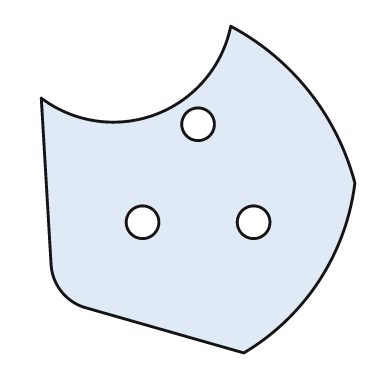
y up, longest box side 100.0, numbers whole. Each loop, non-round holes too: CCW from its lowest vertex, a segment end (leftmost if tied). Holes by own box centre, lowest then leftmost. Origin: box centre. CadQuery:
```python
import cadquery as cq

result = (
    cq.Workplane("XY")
    .moveTo(14.0, -50.0)
    .threePointArc((37.0, -28.0), (48.0, 2.0))
    .threePointArc((34.0, 30.0), (10.0, 50.0))
    .threePointArc((-13.0, 23.0), (-48.0, 28.0))
    .lineTo(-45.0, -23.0)
    .threePointArc((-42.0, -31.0), (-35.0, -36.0))
    .close()
    .moveTo(-17.0, -10.0)
    .circle(5.0)
    .moveTo(17.0, -10.0)
    .circle(5.0)
    .moveTo(0.0, 20.0)
    .circle(5.0)
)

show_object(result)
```